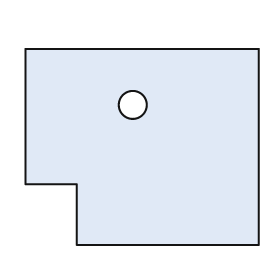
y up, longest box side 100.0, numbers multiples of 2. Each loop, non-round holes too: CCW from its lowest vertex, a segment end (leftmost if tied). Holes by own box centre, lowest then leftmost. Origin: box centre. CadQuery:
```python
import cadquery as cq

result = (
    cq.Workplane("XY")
    .moveTo(-28.0, -42.0)
    .lineTo(50.0, -42.0)
    .lineTo(50.0, 42.0)
    .lineTo(-50.0, 42.0)
    .lineTo(-50.0, -16.0)
    .lineTo(-28.0, -16.0)
    .close()
    .moveTo(-4.0, 18.0)
    .circle(6.0)
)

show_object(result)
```